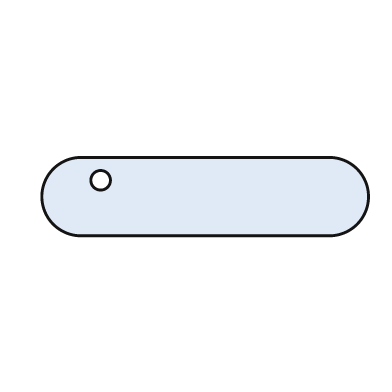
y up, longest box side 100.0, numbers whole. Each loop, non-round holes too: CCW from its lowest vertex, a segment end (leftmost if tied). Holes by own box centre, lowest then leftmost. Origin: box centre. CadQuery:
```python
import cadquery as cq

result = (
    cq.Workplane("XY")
    .moveTo(-38.0, -12.0)
    .lineTo(38.0, -12.0)
    .threePointArc((50.0, 0.0), (38.0, 12.0))
    .lineTo(-38.0, 12.0)
    .threePointArc((-50.0, 0.0), (-38.0, -12.0))
    .close()
    .moveTo(-32.0, 5.0)
    .circle(3.0)
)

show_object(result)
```